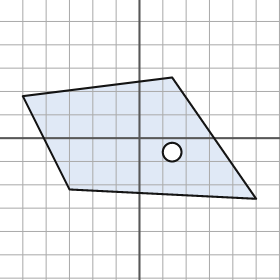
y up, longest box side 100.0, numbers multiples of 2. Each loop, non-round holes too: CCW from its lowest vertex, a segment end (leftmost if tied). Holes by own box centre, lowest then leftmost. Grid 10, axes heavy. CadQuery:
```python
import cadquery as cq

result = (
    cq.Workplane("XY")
    .moveTo(50.0, -26.0)
    .lineTo(14.0, 26.0)
    .lineTo(-50.0, 18.0)
    .lineTo(-30.0, -22.0)
    .close()
    .moveTo(14.0, -6.0)
    .circle(4.0)
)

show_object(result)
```